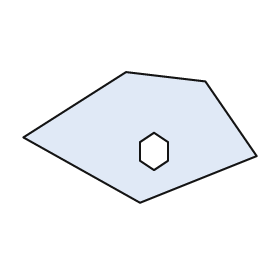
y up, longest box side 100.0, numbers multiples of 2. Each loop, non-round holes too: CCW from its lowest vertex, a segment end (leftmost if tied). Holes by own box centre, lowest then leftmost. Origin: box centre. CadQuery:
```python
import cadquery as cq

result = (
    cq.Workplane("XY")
    .moveTo(0.0, -28.0)
    .lineTo(50.0, -8.0)
    .lineTo(28.0, 24.0)
    .lineTo(-6.0, 28.0)
    .lineTo(-50.0, 0.0)
    .close()
    .moveTo(6.0, -14.0)
    .lineTo(12.0, -10.0)
    .lineTo(12.0, -2.0)
    .lineTo(6.0, 2.0)
    .lineTo(0.0, -2.0)
    .lineTo(0.0, -10.0)
    .close()
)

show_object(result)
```